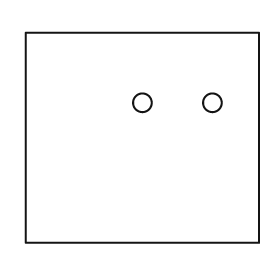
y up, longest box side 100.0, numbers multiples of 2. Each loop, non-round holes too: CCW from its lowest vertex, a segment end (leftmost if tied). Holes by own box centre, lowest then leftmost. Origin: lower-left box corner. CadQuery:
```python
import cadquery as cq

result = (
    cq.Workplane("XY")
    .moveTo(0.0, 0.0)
    .lineTo(100.0, 0.0)
    .lineTo(100.0, 90.0)
    .lineTo(0.0, 90.0)
    .close()
    .moveTo(50.0, 60.0)
    .circle(4.0)
    .moveTo(80.0, 60.0)
    .circle(4.0)
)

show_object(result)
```